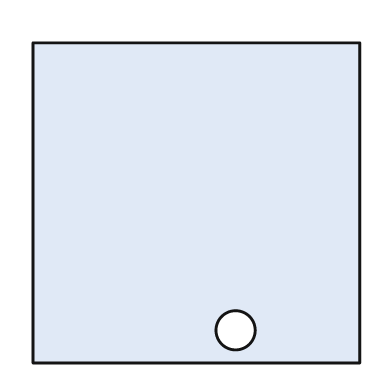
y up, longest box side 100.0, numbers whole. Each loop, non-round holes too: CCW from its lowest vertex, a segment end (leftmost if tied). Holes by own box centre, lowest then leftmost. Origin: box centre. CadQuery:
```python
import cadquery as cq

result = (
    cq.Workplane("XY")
    .moveTo(-50.0, -49.0)
    .lineTo(50.0, -49.0)
    .lineTo(50.0, 49.0)
    .lineTo(-50.0, 49.0)
    .close()
    .moveTo(12.0, -39.0)
    .circle(6.0)
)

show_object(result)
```